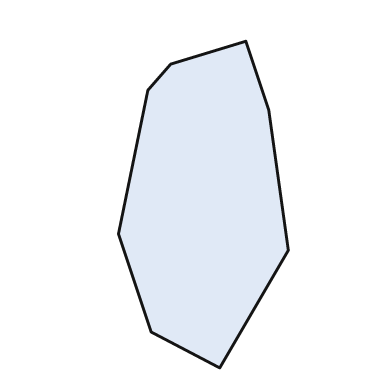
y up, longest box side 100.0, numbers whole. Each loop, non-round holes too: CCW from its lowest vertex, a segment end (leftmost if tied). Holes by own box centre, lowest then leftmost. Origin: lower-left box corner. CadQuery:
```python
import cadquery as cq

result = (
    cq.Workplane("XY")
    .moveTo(31.0, 0.0)
    .lineTo(52.0, 36.0)
    .lineTo(46.0, 79.0)
    .lineTo(39.0, 100.0)
    .lineTo(16.0, 93.0)
    .lineTo(9.0, 85.0)
    .lineTo(0.0, 41.0)
    .lineTo(10.0, 11.0)
    .close()
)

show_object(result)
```